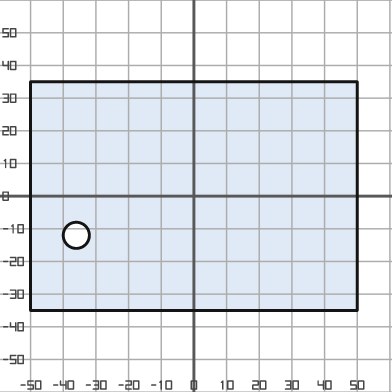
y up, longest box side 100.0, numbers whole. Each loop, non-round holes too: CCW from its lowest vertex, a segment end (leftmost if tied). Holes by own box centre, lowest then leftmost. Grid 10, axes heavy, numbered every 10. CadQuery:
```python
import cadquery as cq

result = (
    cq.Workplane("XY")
    .moveTo(-50.0, -35.0)
    .lineTo(50.0, -35.0)
    .lineTo(50.0, 35.0)
    .lineTo(-50.0, 35.0)
    .close()
    .moveTo(-36.0, -12.0)
    .circle(4.0)
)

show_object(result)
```